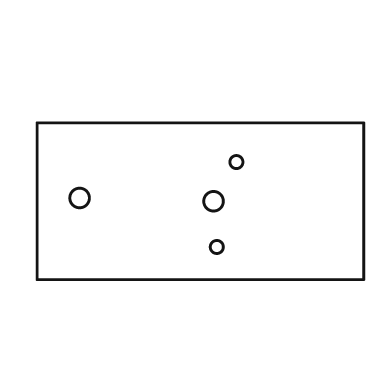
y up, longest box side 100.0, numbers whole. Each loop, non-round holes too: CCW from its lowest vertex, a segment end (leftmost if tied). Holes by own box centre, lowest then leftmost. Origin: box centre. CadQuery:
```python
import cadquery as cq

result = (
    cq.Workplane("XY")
    .moveTo(-50.0, -24.0)
    .lineTo(50.0, -24.0)
    .lineTo(50.0, 24.0)
    .lineTo(-50.0, 24.0)
    .close()
    .moveTo(5.0, -14.0)
    .circle(2.0)
    .moveTo(4.0, 0.0)
    .circle(3.0)
    .moveTo(-37.0, 1.0)
    .circle(3.0)
    .moveTo(11.0, 12.0)
    .circle(2.0)
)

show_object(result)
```